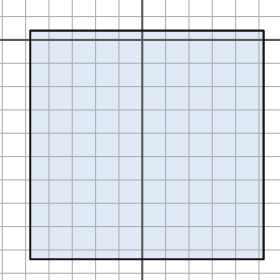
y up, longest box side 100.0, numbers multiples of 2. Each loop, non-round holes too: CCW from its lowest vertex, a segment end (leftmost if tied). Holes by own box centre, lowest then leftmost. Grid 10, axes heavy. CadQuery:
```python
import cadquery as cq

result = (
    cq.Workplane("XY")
    .moveTo(-48.0, -94.0)
    .lineTo(52.0, -94.0)
    .lineTo(52.0, 4.0)
    .lineTo(-48.0, 4.0)
    .close()
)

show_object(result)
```